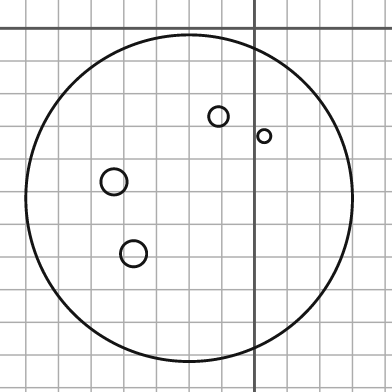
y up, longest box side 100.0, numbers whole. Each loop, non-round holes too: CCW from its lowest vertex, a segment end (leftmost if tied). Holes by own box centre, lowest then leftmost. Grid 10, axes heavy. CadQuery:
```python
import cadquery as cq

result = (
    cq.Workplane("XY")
    .moveTo(-20.0, -52.0)
    .circle(50.0)
    .moveTo(-37.0, -69.0)
    .circle(4.0)
    .moveTo(-43.0, -47.0)
    .circle(4.0)
    .moveTo(3.0, -33.0)
    .circle(2.0)
    .moveTo(-11.0, -27.0)
    .circle(3.0)
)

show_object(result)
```